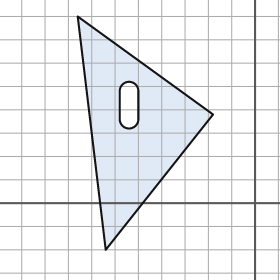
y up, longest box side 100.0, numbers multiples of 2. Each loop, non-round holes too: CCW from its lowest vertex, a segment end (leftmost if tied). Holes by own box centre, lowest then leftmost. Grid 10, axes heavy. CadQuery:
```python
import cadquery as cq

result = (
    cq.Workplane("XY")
    .moveTo(-64.0, -20.0)
    .lineTo(-18.0, 38.0)
    .lineTo(-76.0, 80.0)
    .close()
    .moveTo(-58.0, 36.0)
    .threePointArc((-54.0, 32.0), (-50.0, 36.0))
    .lineTo(-50.0, 48.0)
    .threePointArc((-54.0, 52.0), (-58.0, 48.0))
    .close()
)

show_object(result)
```